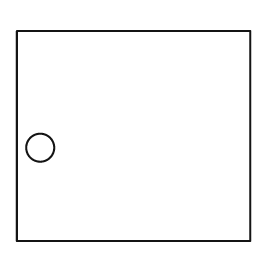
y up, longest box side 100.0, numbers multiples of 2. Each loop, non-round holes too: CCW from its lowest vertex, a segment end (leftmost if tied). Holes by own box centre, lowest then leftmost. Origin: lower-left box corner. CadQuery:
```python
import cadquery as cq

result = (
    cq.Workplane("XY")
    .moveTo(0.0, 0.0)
    .lineTo(100.0, 0.0)
    .lineTo(100.0, 90.0)
    .lineTo(0.0, 90.0)
    .close()
    .moveTo(10.0, 40.0)
    .circle(6.0)
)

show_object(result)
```